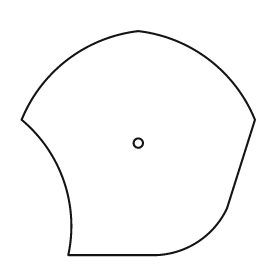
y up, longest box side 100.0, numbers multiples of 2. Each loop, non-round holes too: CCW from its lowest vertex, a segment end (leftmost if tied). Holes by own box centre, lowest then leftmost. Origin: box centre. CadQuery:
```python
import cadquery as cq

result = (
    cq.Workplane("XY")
    .moveTo(-30.0, -48.0)
    .lineTo(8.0, -48.0)
    .threePointArc((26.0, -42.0), (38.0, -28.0))
    .lineTo(50.0, 10.0)
    .threePointArc((30.0, 36.0), (0.0, 48.0))
    .threePointArc((-30.0, 36.0), (-50.0, 10.0))
    .threePointArc((-32.0, -16.0), (-30.0, -48.0))
    .close()
    .moveTo(0.0, 0.0)
    .circle(2.0)
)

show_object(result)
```